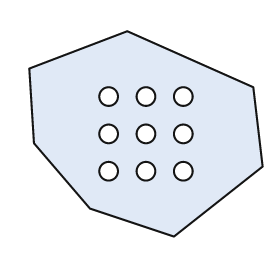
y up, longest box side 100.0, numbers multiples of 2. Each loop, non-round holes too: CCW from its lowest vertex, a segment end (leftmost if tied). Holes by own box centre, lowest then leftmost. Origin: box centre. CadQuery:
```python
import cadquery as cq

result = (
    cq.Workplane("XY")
    .moveTo(12.0, -44.0)
    .lineTo(50.0, -14.0)
    .lineTo(46.0, 20.0)
    .lineTo(-8.0, 44.0)
    .lineTo(-50.0, 28.0)
    .lineTo(-48.0, -4.0)
    .lineTo(-24.0, -32.0)
    .close()
    .moveTo(-16.0, -16.0)
    .circle(4.0)
    .moveTo(0.0, -16.0)
    .circle(4.0)
    .moveTo(16.0, -16.0)
    .circle(4.0)
    .moveTo(-16.0, 0.0)
    .circle(4.0)
    .moveTo(0.0, 0.0)
    .circle(4.0)
    .moveTo(16.0, 0.0)
    .circle(4.0)
    .moveTo(-16.0, 16.0)
    .circle(4.0)
    .moveTo(0.0, 16.0)
    .circle(4.0)
    .moveTo(16.0, 16.0)
    .circle(4.0)
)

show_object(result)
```